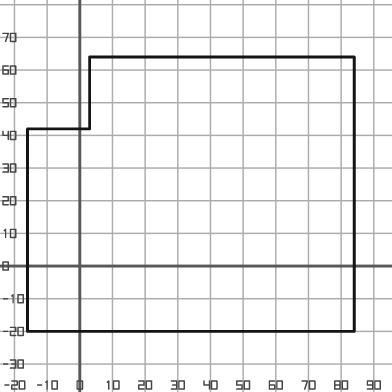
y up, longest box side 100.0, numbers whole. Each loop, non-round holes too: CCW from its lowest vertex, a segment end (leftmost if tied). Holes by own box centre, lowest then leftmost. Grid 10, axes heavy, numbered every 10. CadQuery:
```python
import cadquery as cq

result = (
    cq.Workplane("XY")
    .moveTo(-16.0, -20.0)
    .lineTo(84.0, -20.0)
    .lineTo(84.0, 64.0)
    .lineTo(3.0, 64.0)
    .lineTo(3.0, 42.0)
    .lineTo(-16.0, 42.0)
    .close()
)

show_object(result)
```